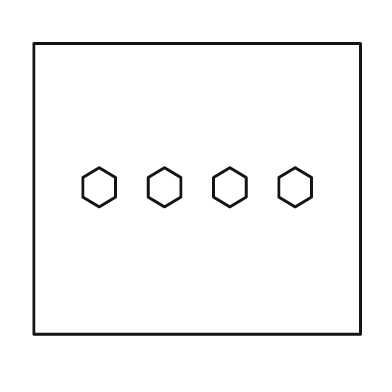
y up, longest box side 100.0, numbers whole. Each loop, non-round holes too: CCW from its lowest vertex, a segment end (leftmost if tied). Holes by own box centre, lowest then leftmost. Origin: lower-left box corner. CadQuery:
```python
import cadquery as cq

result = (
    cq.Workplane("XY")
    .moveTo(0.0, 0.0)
    .lineTo(100.0, 0.0)
    .lineTo(100.0, 89.0)
    .lineTo(0.0, 89.0)
    .close()
    .moveTo(20.0, 39.0)
    .lineTo(25.0, 42.0)
    .lineTo(25.0, 48.0)
    .lineTo(20.0, 51.0)
    .lineTo(15.0, 48.0)
    .lineTo(15.0, 42.0)
    .close()
    .moveTo(40.0, 39.0)
    .lineTo(45.0, 42.0)
    .lineTo(45.0, 48.0)
    .lineTo(40.0, 51.0)
    .lineTo(35.0, 48.0)
    .lineTo(35.0, 42.0)
    .close()
    .moveTo(60.0, 39.0)
    .lineTo(65.0, 42.0)
    .lineTo(65.0, 48.0)
    .lineTo(60.0, 51.0)
    .lineTo(55.0, 48.0)
    .lineTo(55.0, 42.0)
    .close()
    .moveTo(80.0, 39.0)
    .lineTo(85.0, 42.0)
    .lineTo(85.0, 48.0)
    .lineTo(80.0, 51.0)
    .lineTo(75.0, 48.0)
    .lineTo(75.0, 42.0)
    .close()
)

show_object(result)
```